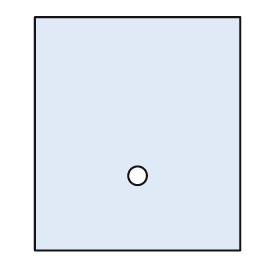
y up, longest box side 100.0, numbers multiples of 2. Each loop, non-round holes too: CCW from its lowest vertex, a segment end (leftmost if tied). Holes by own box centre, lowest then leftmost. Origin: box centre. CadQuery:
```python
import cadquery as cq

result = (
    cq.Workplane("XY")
    .moveTo(-44.0, -50.0)
    .lineTo(44.0, -50.0)
    .lineTo(44.0, 50.0)
    .lineTo(-44.0, 50.0)
    .close()
    .moveTo(0.0, -18.0)
    .circle(4.0)
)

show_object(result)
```